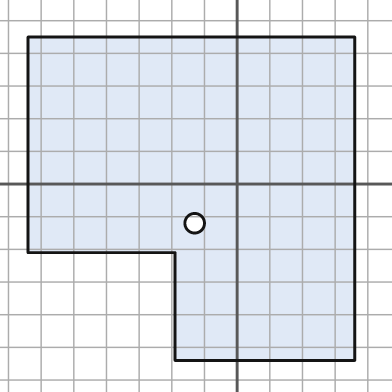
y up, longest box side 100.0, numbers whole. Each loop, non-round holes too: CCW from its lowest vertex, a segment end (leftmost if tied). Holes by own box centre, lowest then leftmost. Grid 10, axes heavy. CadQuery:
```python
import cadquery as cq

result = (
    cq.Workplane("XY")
    .moveTo(-19.0, -54.0)
    .lineTo(36.0, -54.0)
    .lineTo(36.0, 45.0)
    .lineTo(-64.0, 45.0)
    .lineTo(-64.0, -21.0)
    .lineTo(-19.0, -21.0)
    .close()
    .moveTo(-13.0, -12.0)
    .circle(3.0)
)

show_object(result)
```